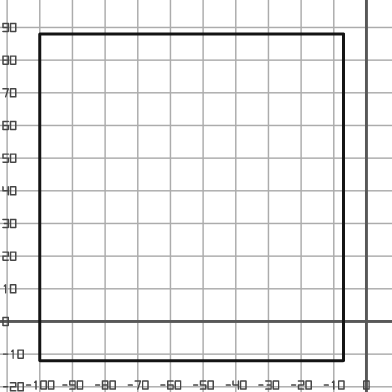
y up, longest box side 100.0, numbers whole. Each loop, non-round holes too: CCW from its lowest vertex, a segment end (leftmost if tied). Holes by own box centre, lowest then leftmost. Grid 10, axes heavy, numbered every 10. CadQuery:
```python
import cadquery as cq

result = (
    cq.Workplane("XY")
    .moveTo(-100.0, -12.0)
    .lineTo(-7.0, -12.0)
    .lineTo(-7.0, 88.0)
    .lineTo(-100.0, 88.0)
    .close()
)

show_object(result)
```